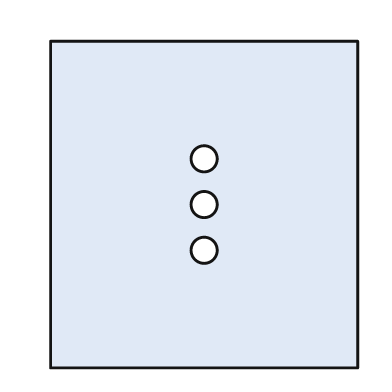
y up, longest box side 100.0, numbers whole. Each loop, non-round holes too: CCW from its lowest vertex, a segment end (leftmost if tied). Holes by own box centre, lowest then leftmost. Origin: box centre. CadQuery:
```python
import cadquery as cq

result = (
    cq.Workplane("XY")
    .moveTo(-47.0, -50.0)
    .lineTo(47.0, -50.0)
    .lineTo(47.0, 50.0)
    .lineTo(-47.0, 50.0)
    .close()
    .moveTo(0.0, -14.0)
    .circle(4.0)
    .moveTo(0.0, 0.0)
    .circle(4.0)
    .moveTo(0.0, 14.0)
    .circle(4.0)
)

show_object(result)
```